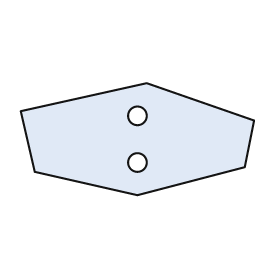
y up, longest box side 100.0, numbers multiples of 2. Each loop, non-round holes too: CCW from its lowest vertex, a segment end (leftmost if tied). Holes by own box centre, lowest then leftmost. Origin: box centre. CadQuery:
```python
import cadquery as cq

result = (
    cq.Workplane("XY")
    .moveTo(0.0, -24.0)
    .lineTo(46.0, -12.0)
    .lineTo(50.0, 8.0)
    .lineTo(4.0, 24.0)
    .lineTo(-50.0, 12.0)
    .lineTo(-44.0, -14.0)
    .close()
    .moveTo(0.0, -10.0)
    .circle(4.0)
    .moveTo(0.0, 10.0)
    .circle(4.0)
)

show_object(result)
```